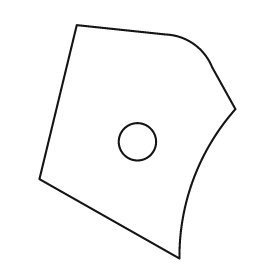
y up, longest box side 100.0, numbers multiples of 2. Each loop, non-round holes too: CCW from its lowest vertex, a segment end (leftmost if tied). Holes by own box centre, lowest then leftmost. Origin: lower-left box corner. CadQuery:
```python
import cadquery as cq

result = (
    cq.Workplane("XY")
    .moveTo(60.0, 0.0)
    .threePointArc((66.0, 34.0), (84.0, 64.0))
    .lineTo(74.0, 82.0)
    .threePointArc((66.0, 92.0), (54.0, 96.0))
    .lineTo(16.0, 100.0)
    .lineTo(0.0, 34.0)
    .close()
    .moveTo(42.0, 50.0)
    .circle(8.0)
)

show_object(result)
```